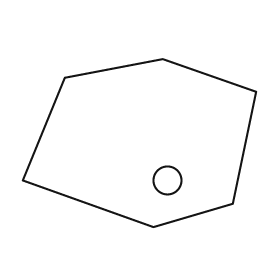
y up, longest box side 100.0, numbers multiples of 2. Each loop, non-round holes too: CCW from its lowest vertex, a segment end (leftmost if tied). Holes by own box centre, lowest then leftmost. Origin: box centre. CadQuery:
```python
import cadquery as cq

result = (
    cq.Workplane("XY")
    .moveTo(6.0, -36.0)
    .lineTo(40.0, -26.0)
    .lineTo(50.0, 22.0)
    .lineTo(10.0, 36.0)
    .lineTo(-32.0, 28.0)
    .lineTo(-50.0, -16.0)
    .close()
    .moveTo(12.0, -16.0)
    .circle(6.0)
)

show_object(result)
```